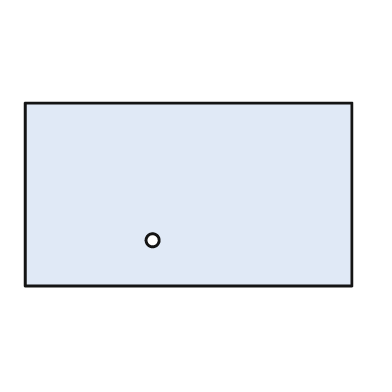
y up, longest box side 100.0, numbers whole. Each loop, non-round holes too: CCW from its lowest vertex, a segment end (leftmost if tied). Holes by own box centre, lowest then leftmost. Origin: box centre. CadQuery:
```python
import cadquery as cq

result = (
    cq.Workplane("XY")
    .moveTo(-50.0, -28.0)
    .lineTo(50.0, -28.0)
    .lineTo(50.0, 28.0)
    .lineTo(-50.0, 28.0)
    .close()
    .moveTo(-11.0, -14.0)
    .circle(2.0)
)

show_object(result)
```